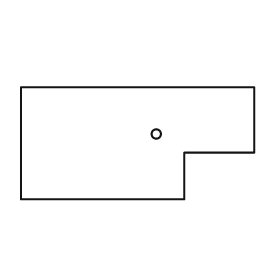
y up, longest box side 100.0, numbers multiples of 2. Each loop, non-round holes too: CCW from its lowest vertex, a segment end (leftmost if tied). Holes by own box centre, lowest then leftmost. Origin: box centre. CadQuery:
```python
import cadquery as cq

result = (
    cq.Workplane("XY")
    .moveTo(-50.0, -24.0)
    .lineTo(20.0, -24.0)
    .lineTo(20.0, -4.0)
    .lineTo(50.0, -4.0)
    .lineTo(50.0, 24.0)
    .lineTo(-50.0, 24.0)
    .close()
    .moveTo(8.0, 4.0)
    .circle(2.0)
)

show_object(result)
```